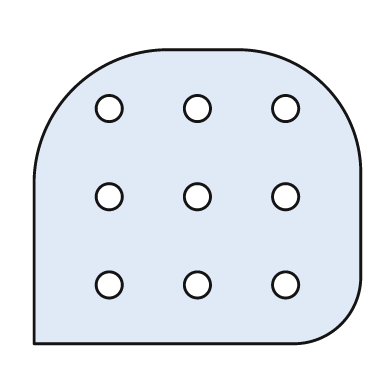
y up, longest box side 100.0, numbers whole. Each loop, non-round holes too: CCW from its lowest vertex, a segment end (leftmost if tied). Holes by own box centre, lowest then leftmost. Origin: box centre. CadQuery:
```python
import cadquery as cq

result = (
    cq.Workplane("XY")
    .moveTo(-50.0, -45.0)
    .lineTo(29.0, -45.0)
    .threePointArc((44.0, -39.0), (50.0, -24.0))
    .lineTo(50.0, 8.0)
    .threePointArc((39.0, 34.0), (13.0, 45.0))
    .lineTo(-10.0, 45.0)
    .threePointArc((-38.0, 33.0), (-50.0, 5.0))
    .close()
    .moveTo(-27.0, -27.0)
    .circle(4.0)
    .moveTo(0.0, -27.0)
    .circle(4.0)
    .moveTo(27.0, -27.0)
    .circle(4.0)
    .moveTo(-27.0, 0.0)
    .circle(4.0)
    .moveTo(0.0, 0.0)
    .circle(4.0)
    .moveTo(27.0, 0.0)
    .circle(4.0)
    .moveTo(-27.0, 27.0)
    .circle(4.0)
    .moveTo(0.0, 27.0)
    .circle(4.0)
    .moveTo(27.0, 27.0)
    .circle(4.0)
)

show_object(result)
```